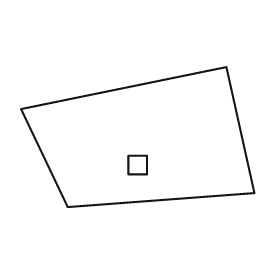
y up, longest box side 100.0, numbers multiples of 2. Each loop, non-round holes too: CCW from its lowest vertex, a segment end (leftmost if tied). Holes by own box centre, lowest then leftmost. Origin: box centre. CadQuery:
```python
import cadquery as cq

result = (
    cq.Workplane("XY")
    .moveTo(-30.0, -30.0)
    .lineTo(50.0, -24.0)
    .lineTo(38.0, 30.0)
    .lineTo(-50.0, 12.0)
    .close()
    .moveTo(-4.0, -16.0)
    .lineTo(4.0, -16.0)
    .lineTo(4.0, -8.0)
    .lineTo(-4.0, -8.0)
    .close()
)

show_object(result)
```